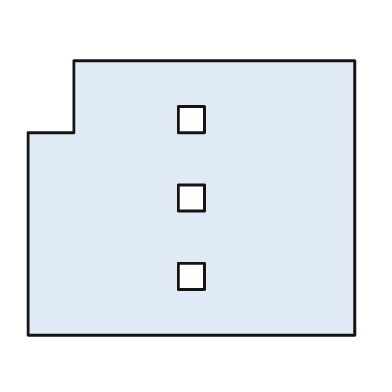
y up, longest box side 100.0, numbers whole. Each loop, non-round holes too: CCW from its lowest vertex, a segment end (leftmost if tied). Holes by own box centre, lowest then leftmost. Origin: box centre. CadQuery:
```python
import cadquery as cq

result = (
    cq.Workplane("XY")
    .moveTo(-50.0, -42.0)
    .lineTo(50.0, -42.0)
    .lineTo(50.0, 42.0)
    .lineTo(-36.0, 42.0)
    .lineTo(-36.0, 20.0)
    .lineTo(-50.0, 20.0)
    .close()
    .moveTo(-4.0, -28.0)
    .lineTo(4.0, -28.0)
    .lineTo(4.0, -20.0)
    .lineTo(-4.0, -20.0)
    .close()
    .moveTo(-4.0, -4.0)
    .lineTo(4.0, -4.0)
    .lineTo(4.0, 4.0)
    .lineTo(-4.0, 4.0)
    .close()
    .moveTo(-4.0, 20.0)
    .lineTo(4.0, 20.0)
    .lineTo(4.0, 28.0)
    .lineTo(-4.0, 28.0)
    .close()
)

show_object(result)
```